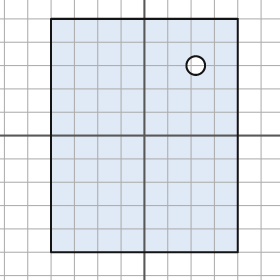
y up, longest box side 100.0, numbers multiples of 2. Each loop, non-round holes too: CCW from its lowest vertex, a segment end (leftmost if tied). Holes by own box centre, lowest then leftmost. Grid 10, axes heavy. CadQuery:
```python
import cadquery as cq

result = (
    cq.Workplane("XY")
    .moveTo(-40.0, -50.0)
    .lineTo(40.0, -50.0)
    .lineTo(40.0, 50.0)
    .lineTo(-40.0, 50.0)
    .close()
    .moveTo(22.0, 30.0)
    .circle(4.0)
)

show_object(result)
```